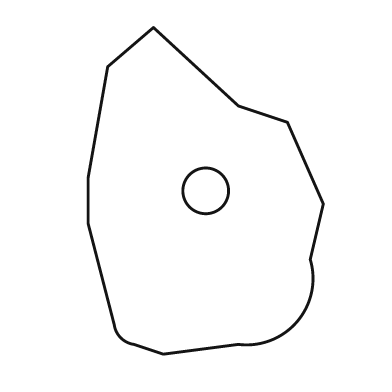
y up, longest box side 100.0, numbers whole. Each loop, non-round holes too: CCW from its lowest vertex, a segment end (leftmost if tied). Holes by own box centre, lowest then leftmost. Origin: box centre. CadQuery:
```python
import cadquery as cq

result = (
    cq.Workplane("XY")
    .moveTo(-13.0, -50.0)
    .lineTo(10.0, -47.0)
    .threePointArc((28.0, -40.0), (32.0, -21.0))
    .lineTo(36.0, -4.0)
    .lineTo(25.0, 21.0)
    .lineTo(10.0, 26.0)
    .lineTo(-16.0, 50.0)
    .lineTo(-30.0, 38.0)
    .lineTo(-36.0, 4.0)
    .lineTo(-36.0, -10.0)
    .lineTo(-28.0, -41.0)
    .threePointArc((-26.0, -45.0), (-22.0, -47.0))
    .close()
    .moveTo(0.0, 0.0)
    .circle(7.0)
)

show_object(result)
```